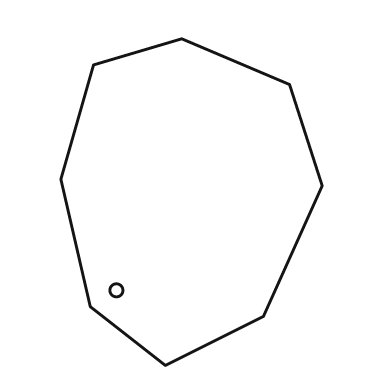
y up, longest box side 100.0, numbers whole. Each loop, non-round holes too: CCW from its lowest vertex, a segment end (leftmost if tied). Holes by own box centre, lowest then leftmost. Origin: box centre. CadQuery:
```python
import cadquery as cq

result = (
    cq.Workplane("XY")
    .moveTo(-8.0, -50.0)
    .lineTo(22.0, -35.0)
    .lineTo(40.0, 5.0)
    .lineTo(30.0, 36.0)
    .lineTo(-3.0, 50.0)
    .lineTo(-30.0, 42.0)
    .lineTo(-40.0, 7.0)
    .lineTo(-31.0, -32.0)
    .close()
    .moveTo(-23.0, -27.0)
    .circle(2.0)
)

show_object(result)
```